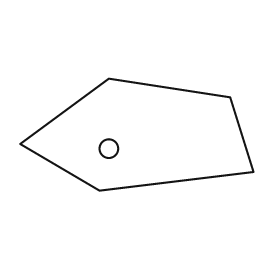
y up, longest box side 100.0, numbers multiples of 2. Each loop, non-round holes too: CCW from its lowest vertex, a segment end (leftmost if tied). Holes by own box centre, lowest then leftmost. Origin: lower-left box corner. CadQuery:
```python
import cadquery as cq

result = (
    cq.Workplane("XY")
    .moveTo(34.0, 0.0)
    .lineTo(100.0, 8.0)
    .lineTo(90.0, 40.0)
    .lineTo(38.0, 48.0)
    .lineTo(0.0, 20.0)
    .close()
    .moveTo(38.0, 18.0)
    .circle(4.0)
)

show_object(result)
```